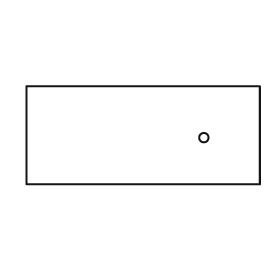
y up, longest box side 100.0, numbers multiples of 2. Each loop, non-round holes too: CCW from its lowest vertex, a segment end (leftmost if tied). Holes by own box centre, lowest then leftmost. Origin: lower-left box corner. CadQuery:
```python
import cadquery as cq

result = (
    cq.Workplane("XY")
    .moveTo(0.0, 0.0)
    .lineTo(100.0, 0.0)
    .lineTo(100.0, 42.0)
    .lineTo(0.0, 42.0)
    .close()
    .moveTo(76.0, 20.0)
    .circle(2.0)
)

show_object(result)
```